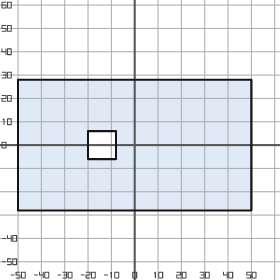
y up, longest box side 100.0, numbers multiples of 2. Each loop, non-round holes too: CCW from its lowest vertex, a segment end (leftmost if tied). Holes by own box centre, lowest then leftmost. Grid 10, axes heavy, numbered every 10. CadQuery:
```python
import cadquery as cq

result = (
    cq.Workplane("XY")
    .moveTo(-50.0, -28.0)
    .lineTo(50.0, -28.0)
    .lineTo(50.0, 28.0)
    .lineTo(-50.0, 28.0)
    .close()
    .moveTo(-20.0, -6.0)
    .lineTo(-8.0, -6.0)
    .lineTo(-8.0, 6.0)
    .lineTo(-20.0, 6.0)
    .close()
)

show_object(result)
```